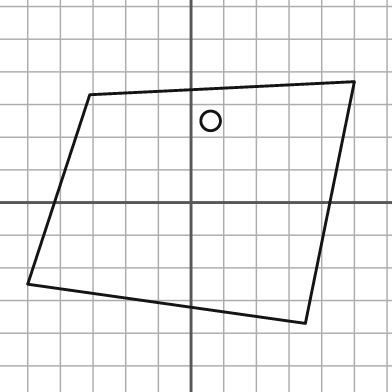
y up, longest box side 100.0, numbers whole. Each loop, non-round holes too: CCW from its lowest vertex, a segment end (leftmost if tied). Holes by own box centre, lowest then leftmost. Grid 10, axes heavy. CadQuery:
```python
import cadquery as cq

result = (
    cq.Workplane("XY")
    .moveTo(35.0, -37.0)
    .lineTo(50.0, 37.0)
    .lineTo(-31.0, 33.0)
    .lineTo(-50.0, -25.0)
    .close()
    .moveTo(6.0, 25.0)
    .circle(3.0)
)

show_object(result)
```